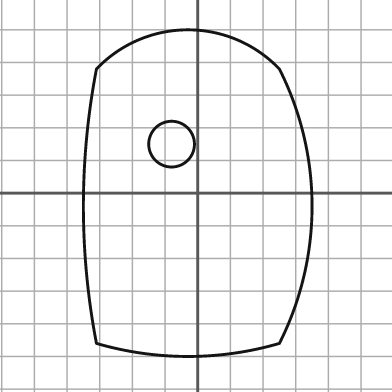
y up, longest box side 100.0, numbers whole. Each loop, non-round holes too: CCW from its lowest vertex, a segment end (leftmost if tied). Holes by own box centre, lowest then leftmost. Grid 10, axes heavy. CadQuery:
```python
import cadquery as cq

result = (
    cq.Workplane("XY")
    .moveTo(-31.0, -46.0)
    .threePointArc((-3.0, -50.0), (25.0, -46.0))
    .threePointArc((35.0, -4.0), (25.0, 38.0))
    .threePointArc((-3.0, 50.0), (-31.0, 38.0))
    .threePointArc((-35.0, -4.0), (-31.0, -46.0))
    .close()
    .moveTo(-8.0, 15.0)
    .circle(7.0)
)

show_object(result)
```